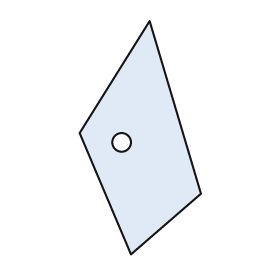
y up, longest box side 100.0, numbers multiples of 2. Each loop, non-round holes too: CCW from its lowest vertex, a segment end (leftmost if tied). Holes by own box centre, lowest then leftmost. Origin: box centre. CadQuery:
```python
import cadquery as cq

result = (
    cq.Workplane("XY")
    .moveTo(-4.0, -50.0)
    .lineTo(26.0, -24.0)
    .lineTo(4.0, 50.0)
    .lineTo(-26.0, 2.0)
    .close()
    .moveTo(-8.0, -2.0)
    .circle(4.0)
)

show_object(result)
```